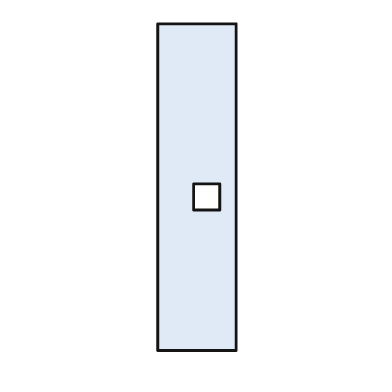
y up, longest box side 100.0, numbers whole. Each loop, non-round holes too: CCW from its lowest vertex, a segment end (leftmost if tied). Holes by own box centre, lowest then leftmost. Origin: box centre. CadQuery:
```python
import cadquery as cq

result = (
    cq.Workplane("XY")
    .moveTo(-12.0, -50.0)
    .lineTo(12.0, -50.0)
    .lineTo(12.0, 50.0)
    .lineTo(-12.0, 50.0)
    .close()
    .moveTo(-1.0, -7.0)
    .lineTo(7.0, -7.0)
    .lineTo(7.0, 1.0)
    .lineTo(-1.0, 1.0)
    .close()
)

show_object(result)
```